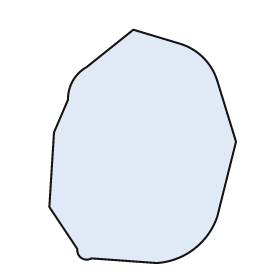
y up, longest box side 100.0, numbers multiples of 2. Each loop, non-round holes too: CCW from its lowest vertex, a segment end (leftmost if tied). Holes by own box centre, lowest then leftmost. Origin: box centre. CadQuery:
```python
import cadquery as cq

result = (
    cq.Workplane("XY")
    .moveTo(6.0, -50.0)
    .threePointArc((22.0, -44.0), (32.0, -30.0))
    .lineTo(40.0, 2.0)
    .lineTo(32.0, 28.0)
    .threePointArc((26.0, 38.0), (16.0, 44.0))
    .lineTo(-4.0, 50.0)
    .lineTo(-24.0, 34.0)
    .threePointArc((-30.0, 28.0), (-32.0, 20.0))
    .lineTo(-38.0, 6.0)
    .lineTo(-40.0, -26.0)
    .lineTo(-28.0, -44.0)
    .threePointArc((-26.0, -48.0), (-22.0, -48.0))
    .close()
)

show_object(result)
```